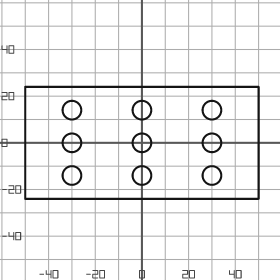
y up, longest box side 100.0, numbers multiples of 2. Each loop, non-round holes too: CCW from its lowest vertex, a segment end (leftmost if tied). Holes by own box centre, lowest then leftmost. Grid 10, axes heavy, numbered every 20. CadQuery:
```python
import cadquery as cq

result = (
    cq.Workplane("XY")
    .moveTo(-50.0, -24.0)
    .lineTo(50.0, -24.0)
    .lineTo(50.0, 24.0)
    .lineTo(-50.0, 24.0)
    .close()
    .moveTo(-30.0, -14.0)
    .circle(4.0)
    .moveTo(0.0, -14.0)
    .circle(4.0)
    .moveTo(30.0, -14.0)
    .circle(4.0)
    .moveTo(-30.0, 0.0)
    .circle(4.0)
    .moveTo(0.0, 0.0)
    .circle(4.0)
    .moveTo(30.0, 0.0)
    .circle(4.0)
    .moveTo(-30.0, 14.0)
    .circle(4.0)
    .moveTo(0.0, 14.0)
    .circle(4.0)
    .moveTo(30.0, 14.0)
    .circle(4.0)
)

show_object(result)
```